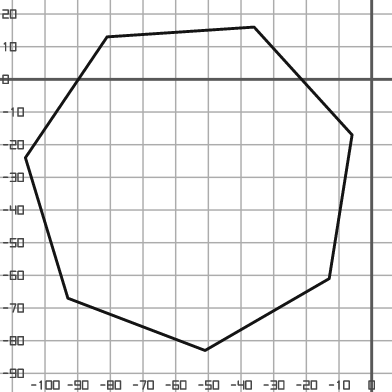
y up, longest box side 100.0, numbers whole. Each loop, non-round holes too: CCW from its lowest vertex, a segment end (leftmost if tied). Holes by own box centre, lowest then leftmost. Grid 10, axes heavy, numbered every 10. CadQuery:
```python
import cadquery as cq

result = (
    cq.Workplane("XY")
    .moveTo(-51.0, -83.0)
    .lineTo(-13.0, -61.0)
    .lineTo(-6.0, -17.0)
    .lineTo(-36.0, 16.0)
    .lineTo(-81.0, 13.0)
    .lineTo(-106.0, -24.0)
    .lineTo(-93.0, -67.0)
    .close()
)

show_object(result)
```